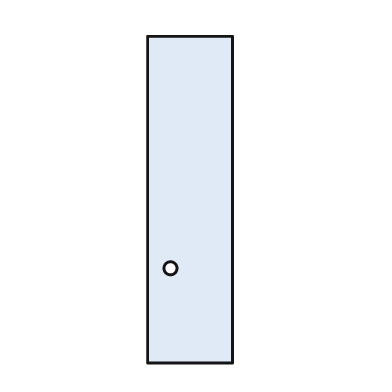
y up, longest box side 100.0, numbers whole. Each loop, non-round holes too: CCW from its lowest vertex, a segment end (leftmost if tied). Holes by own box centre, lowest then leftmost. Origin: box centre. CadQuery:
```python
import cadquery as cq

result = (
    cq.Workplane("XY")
    .moveTo(-13.0, -50.0)
    .lineTo(13.0, -50.0)
    .lineTo(13.0, 50.0)
    .lineTo(-13.0, 50.0)
    .close()
    .moveTo(-6.0, -21.0)
    .circle(2.0)
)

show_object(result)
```